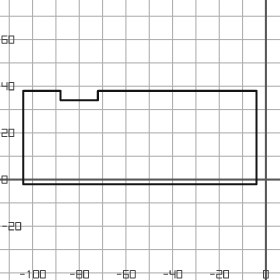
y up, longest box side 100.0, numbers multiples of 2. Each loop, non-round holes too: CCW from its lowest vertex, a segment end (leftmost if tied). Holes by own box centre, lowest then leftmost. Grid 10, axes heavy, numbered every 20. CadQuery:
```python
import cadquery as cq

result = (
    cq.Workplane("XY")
    .moveTo(-104.0, -2.0)
    .lineTo(-4.0, -2.0)
    .lineTo(-4.0, 38.0)
    .lineTo(-72.0, 38.0)
    .lineTo(-72.0, 34.0)
    .lineTo(-88.0, 34.0)
    .lineTo(-88.0, 38.0)
    .lineTo(-104.0, 38.0)
    .close()
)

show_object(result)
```